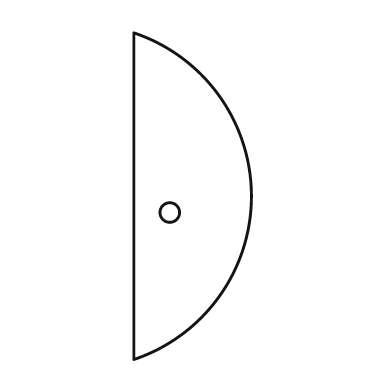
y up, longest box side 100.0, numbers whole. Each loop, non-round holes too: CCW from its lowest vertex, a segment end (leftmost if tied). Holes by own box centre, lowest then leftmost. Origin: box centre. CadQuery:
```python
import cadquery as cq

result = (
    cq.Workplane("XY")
    .moveTo(-18.0, -50.0)
    .threePointArc((18.0, 0.0), (-18.0, 50.0))
    .close()
    .moveTo(-7.0, -5.0)
    .circle(3.0)
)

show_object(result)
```